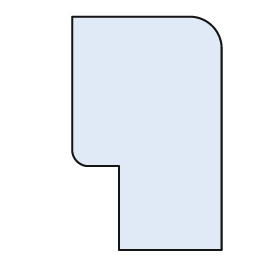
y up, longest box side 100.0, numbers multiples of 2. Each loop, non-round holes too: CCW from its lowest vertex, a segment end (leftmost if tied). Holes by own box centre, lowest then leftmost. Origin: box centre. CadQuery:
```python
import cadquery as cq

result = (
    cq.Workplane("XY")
    .moveTo(-12.0, -50.0)
    .lineTo(32.0, -50.0)
    .lineTo(32.0, 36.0)
    .threePointArc((28.0, 46.0), (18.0, 50.0))
    .lineTo(-32.0, 50.0)
    .lineTo(-32.0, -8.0)
    .threePointArc((-30.0, -12.0), (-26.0, -14.0))
    .lineTo(-12.0, -14.0)
    .close()
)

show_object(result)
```